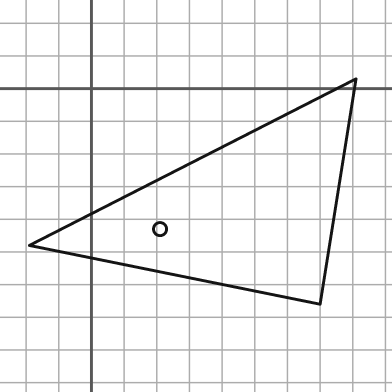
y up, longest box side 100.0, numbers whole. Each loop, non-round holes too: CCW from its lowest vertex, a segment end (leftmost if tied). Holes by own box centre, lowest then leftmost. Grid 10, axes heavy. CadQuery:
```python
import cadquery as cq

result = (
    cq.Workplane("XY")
    .moveTo(70.0, -66.0)
    .lineTo(81.0, 3.0)
    .lineTo(-19.0, -48.0)
    .close()
    .moveTo(21.0, -43.0)
    .circle(2.0)
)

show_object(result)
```